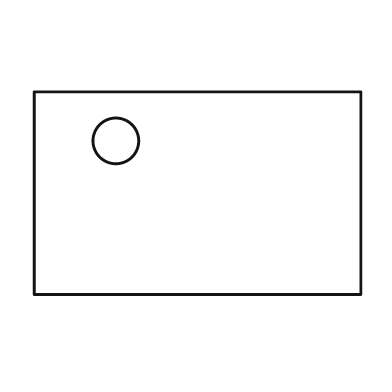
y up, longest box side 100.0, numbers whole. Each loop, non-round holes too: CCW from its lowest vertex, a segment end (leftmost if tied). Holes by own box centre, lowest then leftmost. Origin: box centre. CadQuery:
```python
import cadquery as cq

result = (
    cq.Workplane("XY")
    .moveTo(-50.0, -31.0)
    .lineTo(50.0, -31.0)
    .lineTo(50.0, 31.0)
    .lineTo(-50.0, 31.0)
    .close()
    .moveTo(-25.0, 16.0)
    .circle(7.0)
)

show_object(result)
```